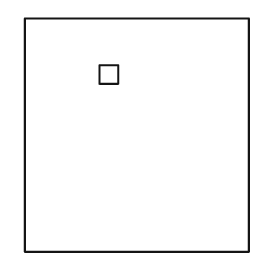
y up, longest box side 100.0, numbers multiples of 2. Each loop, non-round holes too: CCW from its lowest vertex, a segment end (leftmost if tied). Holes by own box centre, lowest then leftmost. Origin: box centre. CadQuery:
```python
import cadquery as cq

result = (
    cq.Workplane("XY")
    .moveTo(-48.0, -50.0)
    .lineTo(48.0, -50.0)
    .lineTo(48.0, 50.0)
    .lineTo(-48.0, 50.0)
    .close()
    .moveTo(-16.0, 22.0)
    .lineTo(-8.0, 22.0)
    .lineTo(-8.0, 30.0)
    .lineTo(-16.0, 30.0)
    .close()
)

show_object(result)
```